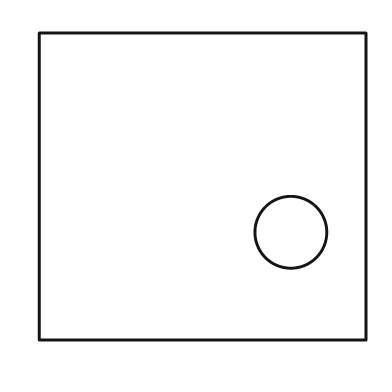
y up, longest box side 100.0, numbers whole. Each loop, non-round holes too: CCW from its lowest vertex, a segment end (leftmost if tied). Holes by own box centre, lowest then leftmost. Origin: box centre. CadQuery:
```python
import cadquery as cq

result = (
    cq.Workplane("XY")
    .moveTo(-50.0, -47.0)
    .lineTo(50.0, -47.0)
    .lineTo(50.0, 47.0)
    .lineTo(-50.0, 47.0)
    .close()
    .moveTo(27.0, -14.0)
    .circle(11.0)
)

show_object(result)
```